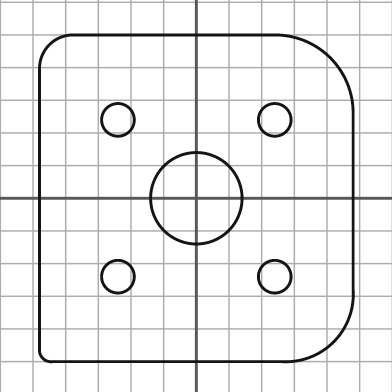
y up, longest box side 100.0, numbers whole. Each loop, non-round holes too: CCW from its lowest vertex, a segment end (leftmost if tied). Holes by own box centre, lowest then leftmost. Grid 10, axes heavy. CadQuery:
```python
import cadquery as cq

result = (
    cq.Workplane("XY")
    .moveTo(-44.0, -50.0)
    .lineTo(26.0, -50.0)
    .threePointArc((42.0, -44.0), (48.0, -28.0))
    .lineTo(48.0, 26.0)
    .threePointArc((41.0, 43.0), (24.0, 50.0))
    .lineTo(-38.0, 50.0)
    .threePointArc((-45.0, 47.0), (-48.0, 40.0))
    .lineTo(-48.0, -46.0)
    .threePointArc((-47.0, -49.0), (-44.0, -50.0))
    .close()
    .moveTo(-24.0, -24.0)
    .circle(5.0)
    .moveTo(24.0, -24.0)
    .circle(5.0)
    .moveTo(0.0, 0.0)
    .circle(14.0)
    .moveTo(-24.0, 24.0)
    .circle(5.0)
    .moveTo(24.0, 24.0)
    .circle(5.0)
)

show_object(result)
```